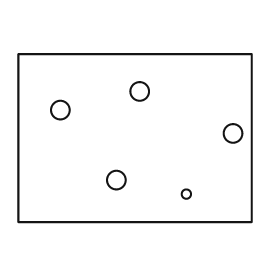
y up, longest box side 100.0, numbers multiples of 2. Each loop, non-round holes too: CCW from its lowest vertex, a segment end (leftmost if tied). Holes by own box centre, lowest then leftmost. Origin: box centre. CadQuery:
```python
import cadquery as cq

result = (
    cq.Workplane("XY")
    .moveTo(-50.0, -36.0)
    .lineTo(50.0, -36.0)
    .lineTo(50.0, 36.0)
    .lineTo(-50.0, 36.0)
    .close()
    .moveTo(22.0, -24.0)
    .circle(2.0)
    .moveTo(-8.0, -18.0)
    .circle(4.0)
    .moveTo(42.0, 2.0)
    .circle(4.0)
    .moveTo(-32.0, 12.0)
    .circle(4.0)
    .moveTo(2.0, 20.0)
    .circle(4.0)
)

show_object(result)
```